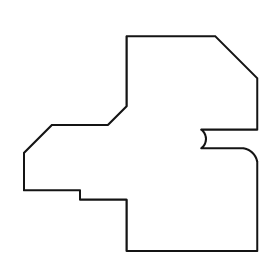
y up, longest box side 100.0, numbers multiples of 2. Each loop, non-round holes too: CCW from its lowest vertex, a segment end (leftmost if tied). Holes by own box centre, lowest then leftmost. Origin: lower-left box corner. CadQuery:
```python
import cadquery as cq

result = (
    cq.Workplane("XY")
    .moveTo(44.0, 0.0)
    .lineTo(100.0, 0.0)
    .lineTo(100.0, 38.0)
    .threePointArc((98.0, 42.0), (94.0, 44.0))
    .lineTo(76.0, 44.0)
    .threePointArc((78.0, 48.0), (76.0, 52.0))
    .lineTo(100.0, 52.0)
    .lineTo(100.0, 74.0)
    .lineTo(82.0, 92.0)
    .lineTo(44.0, 92.0)
    .lineTo(44.0, 62.0)
    .lineTo(36.0, 54.0)
    .lineTo(12.0, 54.0)
    .lineTo(0.0, 42.0)
    .lineTo(0.0, 26.0)
    .lineTo(24.0, 26.0)
    .lineTo(24.0, 22.0)
    .lineTo(44.0, 22.0)
    .close()
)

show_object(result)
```